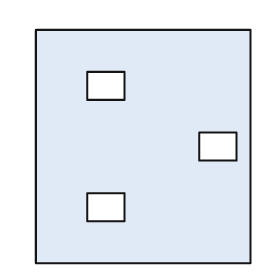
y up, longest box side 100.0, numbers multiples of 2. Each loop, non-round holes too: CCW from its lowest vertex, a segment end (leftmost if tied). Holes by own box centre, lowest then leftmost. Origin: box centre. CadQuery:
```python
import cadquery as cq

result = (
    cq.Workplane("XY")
    .moveTo(-46.0, -50.0)
    .lineTo(46.0, -50.0)
    .lineTo(46.0, 50.0)
    .lineTo(-46.0, 50.0)
    .close()
    .moveTo(-24.0, -32.0)
    .lineTo(-8.0, -32.0)
    .lineTo(-8.0, -20.0)
    .lineTo(-24.0, -20.0)
    .close()
    .moveTo(24.0, -6.0)
    .lineTo(40.0, -6.0)
    .lineTo(40.0, 6.0)
    .lineTo(24.0, 6.0)
    .close()
    .moveTo(-24.0, 20.0)
    .lineTo(-8.0, 20.0)
    .lineTo(-8.0, 32.0)
    .lineTo(-24.0, 32.0)
    .close()
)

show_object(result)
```